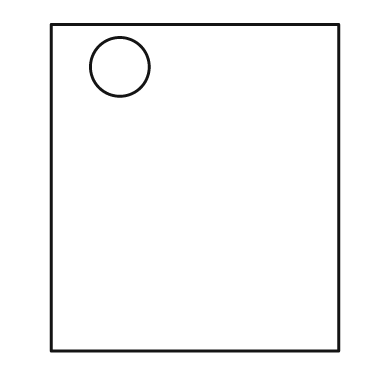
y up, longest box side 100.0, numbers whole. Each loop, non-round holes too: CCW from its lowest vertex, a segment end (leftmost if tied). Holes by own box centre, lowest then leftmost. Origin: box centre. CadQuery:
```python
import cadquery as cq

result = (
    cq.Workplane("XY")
    .moveTo(-44.0, -50.0)
    .lineTo(44.0, -50.0)
    .lineTo(44.0, 50.0)
    .lineTo(-44.0, 50.0)
    .close()
    .moveTo(-23.0, 37.0)
    .circle(9.0)
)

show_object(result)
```